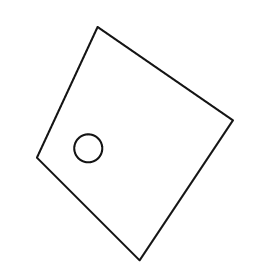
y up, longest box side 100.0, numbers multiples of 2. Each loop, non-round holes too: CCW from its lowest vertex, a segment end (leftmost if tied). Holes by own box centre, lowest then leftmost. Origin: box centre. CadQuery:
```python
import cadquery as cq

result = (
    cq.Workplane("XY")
    .moveTo(2.0, -50.0)
    .lineTo(42.0, 10.0)
    .lineTo(-16.0, 50.0)
    .lineTo(-42.0, -6.0)
    .close()
    .moveTo(-20.0, -2.0)
    .circle(6.0)
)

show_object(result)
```